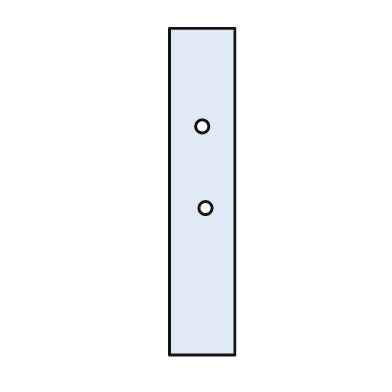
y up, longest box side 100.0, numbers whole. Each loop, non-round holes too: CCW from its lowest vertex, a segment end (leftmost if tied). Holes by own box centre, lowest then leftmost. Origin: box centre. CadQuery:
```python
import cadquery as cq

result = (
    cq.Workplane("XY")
    .moveTo(-10.0, -50.0)
    .lineTo(10.0, -50.0)
    .lineTo(10.0, 50.0)
    .lineTo(-10.0, 50.0)
    .close()
    .moveTo(1.0, -5.0)
    .circle(2.0)
    .moveTo(0.0, 20.0)
    .circle(2.0)
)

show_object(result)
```